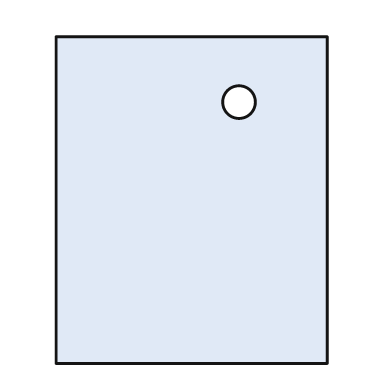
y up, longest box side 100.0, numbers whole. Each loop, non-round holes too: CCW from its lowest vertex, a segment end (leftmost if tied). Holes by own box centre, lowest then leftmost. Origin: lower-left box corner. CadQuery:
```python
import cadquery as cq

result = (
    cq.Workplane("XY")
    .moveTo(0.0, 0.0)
    .lineTo(83.0, 0.0)
    .lineTo(83.0, 100.0)
    .lineTo(0.0, 100.0)
    .close()
    .moveTo(56.0, 80.0)
    .circle(5.0)
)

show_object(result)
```